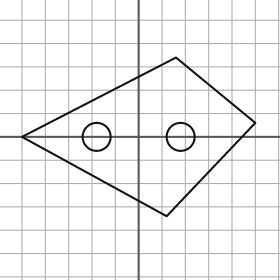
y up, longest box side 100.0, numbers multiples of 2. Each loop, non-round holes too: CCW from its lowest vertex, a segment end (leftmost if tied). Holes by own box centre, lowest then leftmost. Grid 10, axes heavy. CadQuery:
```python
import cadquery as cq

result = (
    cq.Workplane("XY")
    .moveTo(12.0, -34.0)
    .lineTo(50.0, 6.0)
    .lineTo(16.0, 34.0)
    .lineTo(-50.0, 0.0)
    .close()
    .moveTo(-18.0, 0.0)
    .circle(6.0)
    .moveTo(18.0, 0.0)
    .circle(6.0)
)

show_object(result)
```